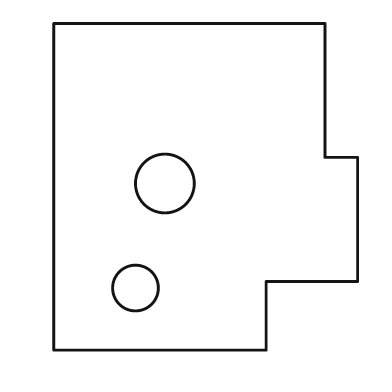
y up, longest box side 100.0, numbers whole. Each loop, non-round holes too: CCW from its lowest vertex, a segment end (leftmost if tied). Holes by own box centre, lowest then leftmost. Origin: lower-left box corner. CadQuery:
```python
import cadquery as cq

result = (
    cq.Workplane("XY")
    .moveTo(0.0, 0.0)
    .lineTo(65.0, 0.0)
    .lineTo(65.0, 21.0)
    .lineTo(93.0, 21.0)
    .lineTo(93.0, 59.0)
    .lineTo(83.0, 59.0)
    .lineTo(83.0, 100.0)
    .lineTo(0.0, 100.0)
    .close()
    .moveTo(25.0, 19.0)
    .circle(7.0)
    .moveTo(34.0, 51.0)
    .circle(9.0)
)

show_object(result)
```